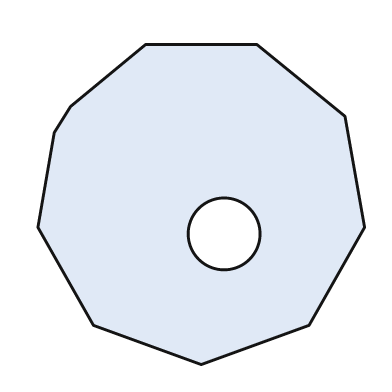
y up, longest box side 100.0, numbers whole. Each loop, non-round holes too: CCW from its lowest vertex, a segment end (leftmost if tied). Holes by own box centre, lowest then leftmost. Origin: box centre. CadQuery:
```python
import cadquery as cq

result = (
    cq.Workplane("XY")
    .moveTo(0.0, -49.0)
    .lineTo(33.0, -37.0)
    .lineTo(50.0, -7.0)
    .lineTo(44.0, 27.0)
    .lineTo(17.0, 49.0)
    .lineTo(-17.0, 49.0)
    .lineTo(-40.0, 30.0)
    .lineTo(-45.0, 22.0)
    .lineTo(-50.0, -7.0)
    .lineTo(-33.0, -37.0)
    .close()
    .moveTo(7.0, -9.0)
    .circle(11.0)
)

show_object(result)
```